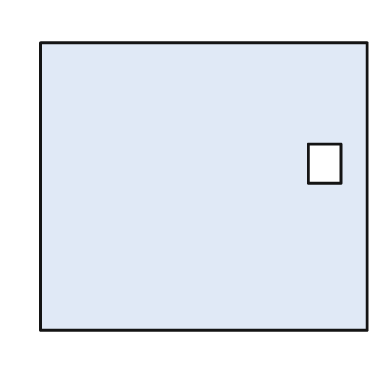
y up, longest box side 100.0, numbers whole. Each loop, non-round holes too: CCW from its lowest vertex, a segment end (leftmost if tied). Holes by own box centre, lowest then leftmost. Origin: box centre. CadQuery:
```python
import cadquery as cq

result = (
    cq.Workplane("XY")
    .moveTo(-50.0, -44.0)
    .lineTo(50.0, -44.0)
    .lineTo(50.0, 44.0)
    .lineTo(-50.0, 44.0)
    .close()
    .moveTo(32.0, 1.0)
    .lineTo(42.0, 1.0)
    .lineTo(42.0, 13.0)
    .lineTo(32.0, 13.0)
    .close()
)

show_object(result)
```